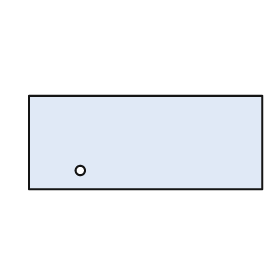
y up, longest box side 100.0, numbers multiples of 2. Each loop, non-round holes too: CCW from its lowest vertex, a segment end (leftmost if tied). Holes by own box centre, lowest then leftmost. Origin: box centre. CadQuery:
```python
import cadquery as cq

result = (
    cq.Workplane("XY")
    .moveTo(-50.0, -20.0)
    .lineTo(50.0, -20.0)
    .lineTo(50.0, 20.0)
    .lineTo(-50.0, 20.0)
    .close()
    .moveTo(-28.0, -12.0)
    .circle(2.0)
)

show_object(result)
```